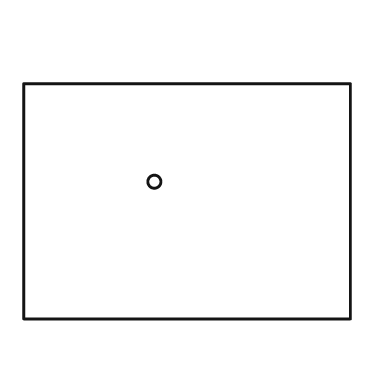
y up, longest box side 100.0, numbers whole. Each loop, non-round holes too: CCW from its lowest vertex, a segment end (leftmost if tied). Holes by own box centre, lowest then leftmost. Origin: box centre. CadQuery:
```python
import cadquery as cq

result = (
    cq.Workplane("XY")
    .moveTo(-50.0, -36.0)
    .lineTo(50.0, -36.0)
    .lineTo(50.0, 36.0)
    .lineTo(-50.0, 36.0)
    .close()
    .moveTo(-10.0, 6.0)
    .circle(2.0)
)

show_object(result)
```